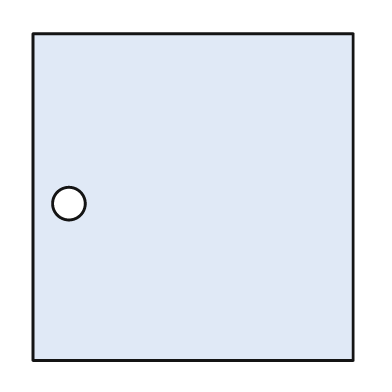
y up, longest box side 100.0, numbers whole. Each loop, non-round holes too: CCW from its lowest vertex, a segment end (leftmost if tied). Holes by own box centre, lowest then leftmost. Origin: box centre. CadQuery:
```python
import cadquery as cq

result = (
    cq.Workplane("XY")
    .moveTo(-49.0, -50.0)
    .lineTo(49.0, -50.0)
    .lineTo(49.0, 50.0)
    .lineTo(-49.0, 50.0)
    .close()
    .moveTo(-38.0, -2.0)
    .circle(5.0)
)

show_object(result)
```